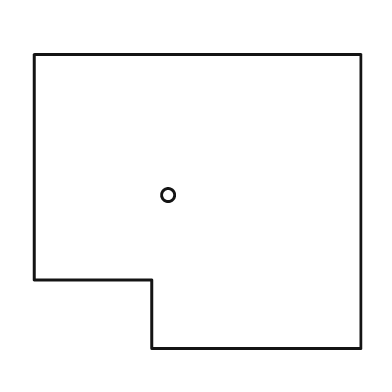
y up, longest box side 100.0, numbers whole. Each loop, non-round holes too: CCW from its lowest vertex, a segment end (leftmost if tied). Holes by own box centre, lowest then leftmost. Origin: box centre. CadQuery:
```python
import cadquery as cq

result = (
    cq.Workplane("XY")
    .moveTo(-14.0, -45.0)
    .lineTo(50.0, -45.0)
    .lineTo(50.0, 45.0)
    .lineTo(-50.0, 45.0)
    .lineTo(-50.0, -24.0)
    .lineTo(-14.0, -24.0)
    .close()
    .moveTo(-9.0, 2.0)
    .circle(2.0)
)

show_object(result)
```